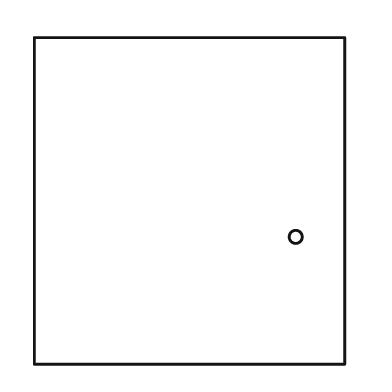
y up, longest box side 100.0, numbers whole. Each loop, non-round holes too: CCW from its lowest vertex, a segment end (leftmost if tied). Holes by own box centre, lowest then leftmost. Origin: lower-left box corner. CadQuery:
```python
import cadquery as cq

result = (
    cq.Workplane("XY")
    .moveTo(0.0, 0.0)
    .lineTo(95.0, 0.0)
    .lineTo(95.0, 100.0)
    .lineTo(0.0, 100.0)
    .close()
    .moveTo(80.0, 39.0)
    .circle(2.0)
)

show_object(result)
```